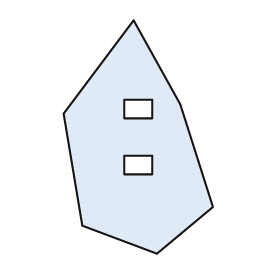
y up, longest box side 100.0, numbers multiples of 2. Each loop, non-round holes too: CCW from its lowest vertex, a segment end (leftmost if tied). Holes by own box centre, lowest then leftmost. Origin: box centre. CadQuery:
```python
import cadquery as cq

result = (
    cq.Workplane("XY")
    .moveTo(8.0, -50.0)
    .lineTo(32.0, -30.0)
    .lineTo(18.0, 14.0)
    .lineTo(-2.0, 50.0)
    .lineTo(-32.0, 10.0)
    .lineTo(-24.0, -38.0)
    .close()
    .moveTo(-6.0, -16.0)
    .lineTo(6.0, -16.0)
    .lineTo(6.0, -8.0)
    .lineTo(-6.0, -8.0)
    .close()
    .moveTo(-6.0, 8.0)
    .lineTo(6.0, 8.0)
    .lineTo(6.0, 16.0)
    .lineTo(-6.0, 16.0)
    .close()
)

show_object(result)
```